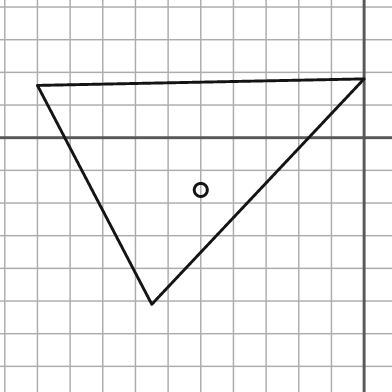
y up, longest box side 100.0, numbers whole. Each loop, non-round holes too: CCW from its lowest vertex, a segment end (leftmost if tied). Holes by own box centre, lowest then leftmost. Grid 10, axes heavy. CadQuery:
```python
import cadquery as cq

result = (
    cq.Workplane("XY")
    .moveTo(-65.0, -51.0)
    .lineTo(0.0, 18.0)
    .lineTo(-100.0, 16.0)
    .close()
    .moveTo(-50.0, -16.0)
    .circle(2.0)
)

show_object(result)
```